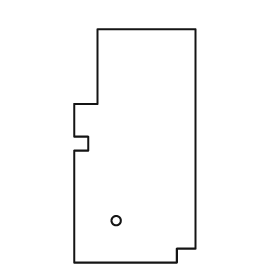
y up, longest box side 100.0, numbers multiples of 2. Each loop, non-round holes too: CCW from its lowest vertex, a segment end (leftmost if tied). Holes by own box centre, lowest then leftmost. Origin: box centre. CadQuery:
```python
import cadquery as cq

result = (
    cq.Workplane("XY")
    .moveTo(-26.0, -50.0)
    .lineTo(18.0, -50.0)
    .lineTo(18.0, -44.0)
    .lineTo(26.0, -44.0)
    .lineTo(26.0, 50.0)
    .lineTo(-16.0, 50.0)
    .lineTo(-16.0, 18.0)
    .lineTo(-26.0, 18.0)
    .lineTo(-26.0, 4.0)
    .lineTo(-20.0, 4.0)
    .lineTo(-20.0, -2.0)
    .lineTo(-26.0, -2.0)
    .close()
    .moveTo(-8.0, -32.0)
    .circle(2.0)
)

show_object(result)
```